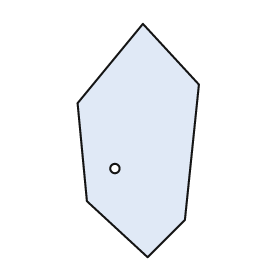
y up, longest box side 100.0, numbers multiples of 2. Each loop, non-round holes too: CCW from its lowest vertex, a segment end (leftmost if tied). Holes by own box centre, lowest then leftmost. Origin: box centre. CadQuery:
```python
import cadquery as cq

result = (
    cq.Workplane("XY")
    .moveTo(4.0, -50.0)
    .lineTo(20.0, -34.0)
    .lineTo(26.0, 24.0)
    .lineTo(2.0, 50.0)
    .lineTo(-26.0, 16.0)
    .lineTo(-22.0, -26.0)
    .close()
    .moveTo(-10.0, -12.0)
    .circle(2.0)
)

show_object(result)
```